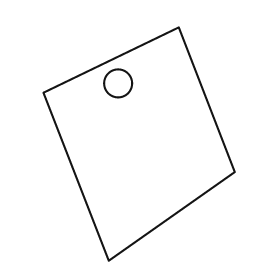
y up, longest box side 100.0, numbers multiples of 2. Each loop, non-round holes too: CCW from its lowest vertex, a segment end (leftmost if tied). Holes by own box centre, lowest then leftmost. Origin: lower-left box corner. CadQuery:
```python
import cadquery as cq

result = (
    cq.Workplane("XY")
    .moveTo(28.0, 0.0)
    .lineTo(82.0, 38.0)
    .lineTo(58.0, 100.0)
    .lineTo(0.0, 72.0)
    .close()
    .moveTo(32.0, 76.0)
    .circle(6.0)
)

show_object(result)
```